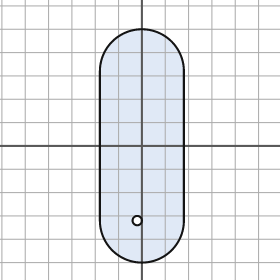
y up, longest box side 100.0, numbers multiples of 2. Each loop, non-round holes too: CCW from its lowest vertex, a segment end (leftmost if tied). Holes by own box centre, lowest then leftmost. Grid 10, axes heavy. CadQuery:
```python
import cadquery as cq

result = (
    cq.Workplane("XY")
    .moveTo(-18.0, -32.0)
    .threePointArc((0.0, -50.0), (18.0, -32.0))
    .lineTo(18.0, 32.0)
    .threePointArc((0.0, 50.0), (-18.0, 32.0))
    .close()
    .moveTo(-2.0, -32.0)
    .circle(2.0)
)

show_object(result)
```